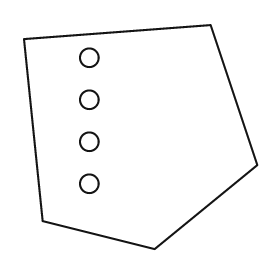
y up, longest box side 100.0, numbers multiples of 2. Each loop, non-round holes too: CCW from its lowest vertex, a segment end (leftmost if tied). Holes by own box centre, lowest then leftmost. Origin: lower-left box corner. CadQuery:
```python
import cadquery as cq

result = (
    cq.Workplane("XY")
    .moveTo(56.0, 0.0)
    .lineTo(100.0, 36.0)
    .lineTo(80.0, 96.0)
    .lineTo(0.0, 90.0)
    .lineTo(8.0, 12.0)
    .close()
    .moveTo(28.0, 28.0)
    .circle(4.0)
    .moveTo(28.0, 46.0)
    .circle(4.0)
    .moveTo(28.0, 64.0)
    .circle(4.0)
    .moveTo(28.0, 82.0)
    .circle(4.0)
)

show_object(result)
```